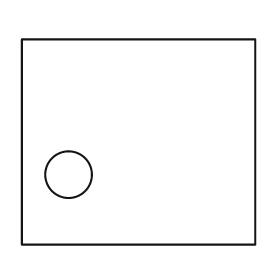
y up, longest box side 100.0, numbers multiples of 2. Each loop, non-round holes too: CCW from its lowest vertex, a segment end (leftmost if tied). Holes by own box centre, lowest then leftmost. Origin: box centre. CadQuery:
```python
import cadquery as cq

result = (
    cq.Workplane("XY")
    .moveTo(-50.0, -44.0)
    .lineTo(50.0, -44.0)
    .lineTo(50.0, 44.0)
    .lineTo(-50.0, 44.0)
    .close()
    .moveTo(-30.0, -14.0)
    .circle(10.0)
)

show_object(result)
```